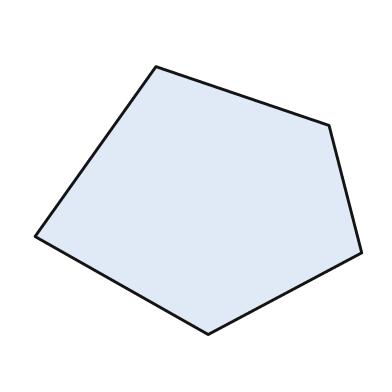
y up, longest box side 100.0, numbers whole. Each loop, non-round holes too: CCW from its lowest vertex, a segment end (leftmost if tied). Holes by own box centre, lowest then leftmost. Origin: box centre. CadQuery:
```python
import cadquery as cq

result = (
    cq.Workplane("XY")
    .moveTo(3.0, -41.0)
    .lineTo(50.0, -16.0)
    .lineTo(40.0, 23.0)
    .lineTo(-13.0, 41.0)
    .lineTo(-50.0, -11.0)
    .close()
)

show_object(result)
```